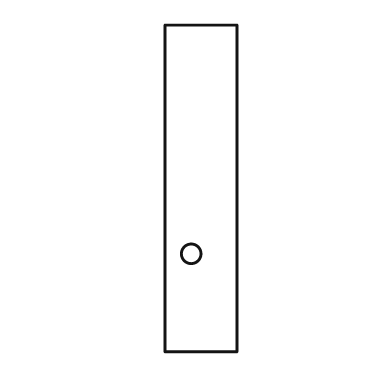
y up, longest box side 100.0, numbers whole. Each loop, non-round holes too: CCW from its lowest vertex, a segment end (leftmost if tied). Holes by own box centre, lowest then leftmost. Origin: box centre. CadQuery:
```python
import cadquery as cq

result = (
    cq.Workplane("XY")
    .moveTo(-11.0, -50.0)
    .lineTo(11.0, -50.0)
    .lineTo(11.0, 50.0)
    .lineTo(-11.0, 50.0)
    .close()
    .moveTo(-3.0, -20.0)
    .circle(3.0)
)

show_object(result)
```